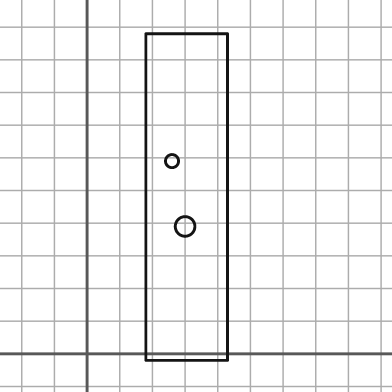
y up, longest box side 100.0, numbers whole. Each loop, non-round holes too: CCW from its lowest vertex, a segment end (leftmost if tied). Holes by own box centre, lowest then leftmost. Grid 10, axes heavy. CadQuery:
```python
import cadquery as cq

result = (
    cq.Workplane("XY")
    .moveTo(18.0, -2.0)
    .lineTo(43.0, -2.0)
    .lineTo(43.0, 98.0)
    .lineTo(18.0, 98.0)
    .close()
    .moveTo(30.0, 39.0)
    .circle(3.0)
    .moveTo(26.0, 59.0)
    .circle(2.0)
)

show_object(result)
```